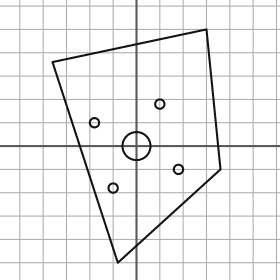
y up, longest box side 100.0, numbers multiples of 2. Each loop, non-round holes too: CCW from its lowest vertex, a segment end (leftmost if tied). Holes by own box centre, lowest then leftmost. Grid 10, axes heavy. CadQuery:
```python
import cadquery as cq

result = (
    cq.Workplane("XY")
    .moveTo(-8.0, -50.0)
    .lineTo(36.0, -10.0)
    .lineTo(30.0, 50.0)
    .lineTo(-36.0, 36.0)
    .close()
    .moveTo(-10.0, -18.0)
    .circle(2.0)
    .moveTo(18.0, -10.0)
    .circle(2.0)
    .moveTo(0.0, 0.0)
    .circle(6.0)
    .moveTo(-18.0, 10.0)
    .circle(2.0)
    .moveTo(10.0, 18.0)
    .circle(2.0)
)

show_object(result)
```